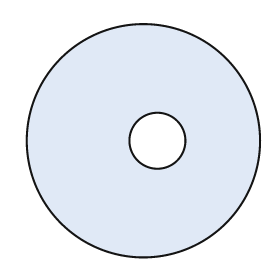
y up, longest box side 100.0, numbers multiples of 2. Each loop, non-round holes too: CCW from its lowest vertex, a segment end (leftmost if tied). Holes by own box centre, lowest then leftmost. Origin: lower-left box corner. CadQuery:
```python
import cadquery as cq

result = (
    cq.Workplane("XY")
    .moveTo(50.0, 50.0)
    .circle(50.0)
    .moveTo(56.0, 50.0)
    .circle(12.0)
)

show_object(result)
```